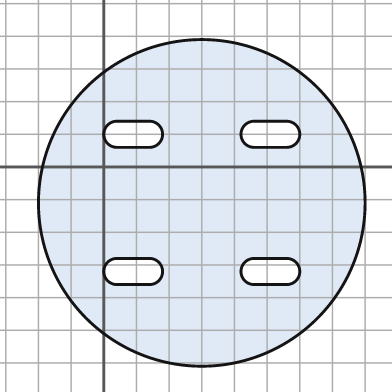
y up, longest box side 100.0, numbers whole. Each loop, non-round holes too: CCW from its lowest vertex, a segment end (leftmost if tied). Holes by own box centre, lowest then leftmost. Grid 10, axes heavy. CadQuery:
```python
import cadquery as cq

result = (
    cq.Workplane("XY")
    .moveTo(30.0, -11.0)
    .circle(50.0)
    .moveTo(4.0, -36.0)
    .lineTo(14.0, -36.0)
    .threePointArc((18.0, -32.0), (14.0, -28.0))
    .lineTo(4.0, -28.0)
    .threePointArc((0.0, -32.0), (4.0, -36.0))
    .close()
    .moveTo(46.0, -36.0)
    .lineTo(56.0, -36.0)
    .threePointArc((60.0, -32.0), (56.0, -28.0))
    .lineTo(46.0, -28.0)
    .threePointArc((42.0, -32.0), (46.0, -36.0))
    .close()
    .moveTo(4.0, 6.0)
    .lineTo(14.0, 6.0)
    .threePointArc((18.0, 10.0), (14.0, 14.0))
    .lineTo(4.0, 14.0)
    .threePointArc((0.0, 10.0), (4.0, 6.0))
    .close()
    .moveTo(46.0, 6.0)
    .lineTo(56.0, 6.0)
    .threePointArc((60.0, 10.0), (56.0, 14.0))
    .lineTo(46.0, 14.0)
    .threePointArc((42.0, 10.0), (46.0, 6.0))
    .close()
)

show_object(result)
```